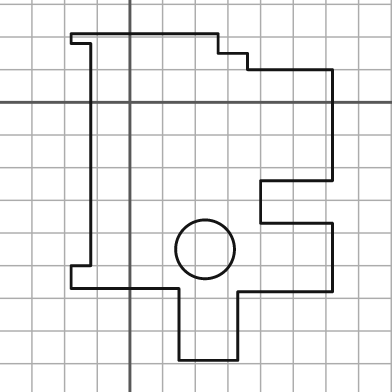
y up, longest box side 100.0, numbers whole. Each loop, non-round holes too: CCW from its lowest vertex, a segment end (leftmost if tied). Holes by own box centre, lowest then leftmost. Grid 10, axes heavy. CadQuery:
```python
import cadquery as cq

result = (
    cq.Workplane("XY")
    .moveTo(15.0, -79.0)
    .lineTo(33.0, -79.0)
    .lineTo(33.0, -58.0)
    .lineTo(62.0, -58.0)
    .lineTo(62.0, -37.0)
    .lineTo(40.0, -37.0)
    .lineTo(40.0, -24.0)
    .lineTo(62.0, -24.0)
    .lineTo(62.0, 10.0)
    .lineTo(36.0, 10.0)
    .lineTo(36.0, 15.0)
    .lineTo(27.0, 15.0)
    .lineTo(27.0, 21.0)
    .lineTo(-18.0, 21.0)
    .lineTo(-18.0, 18.0)
    .lineTo(-12.0, 18.0)
    .lineTo(-12.0, -50.0)
    .lineTo(-18.0, -50.0)
    .lineTo(-18.0, -57.0)
    .lineTo(15.0, -57.0)
    .close()
    .moveTo(23.0, -45.0)
    .circle(9.0)
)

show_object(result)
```